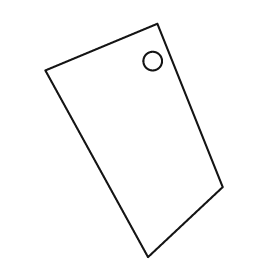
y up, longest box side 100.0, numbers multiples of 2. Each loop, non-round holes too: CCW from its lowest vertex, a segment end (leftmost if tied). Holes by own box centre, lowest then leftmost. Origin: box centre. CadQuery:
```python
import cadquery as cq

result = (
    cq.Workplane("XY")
    .moveTo(6.0, -50.0)
    .lineTo(38.0, -20.0)
    .lineTo(10.0, 50.0)
    .lineTo(-38.0, 30.0)
    .close()
    .moveTo(8.0, 34.0)
    .circle(4.0)
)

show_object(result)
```